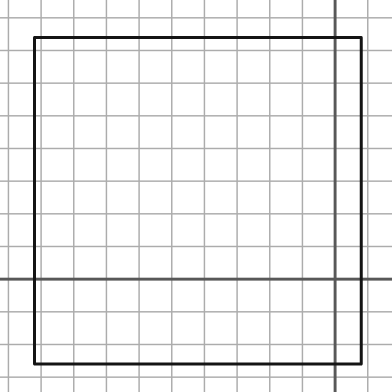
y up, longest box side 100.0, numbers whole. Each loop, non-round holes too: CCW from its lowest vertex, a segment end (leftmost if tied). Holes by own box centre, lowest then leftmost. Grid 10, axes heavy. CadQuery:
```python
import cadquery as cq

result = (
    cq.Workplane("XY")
    .moveTo(-92.0, -26.0)
    .lineTo(8.0, -26.0)
    .lineTo(8.0, 74.0)
    .lineTo(-92.0, 74.0)
    .close()
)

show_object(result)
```